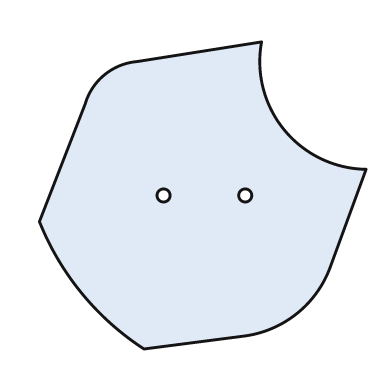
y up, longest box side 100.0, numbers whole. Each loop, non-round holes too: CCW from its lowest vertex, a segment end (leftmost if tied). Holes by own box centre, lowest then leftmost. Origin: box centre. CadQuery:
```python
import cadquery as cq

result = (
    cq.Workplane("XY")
    .moveTo(-18.0, -47.0)
    .lineTo(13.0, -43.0)
    .threePointArc((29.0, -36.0), (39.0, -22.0))
    .lineTo(50.0, 8.0)
    .threePointArc((25.0, 20.0), (18.0, 47.0))
    .lineTo(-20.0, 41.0)
    .threePointArc((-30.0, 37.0), (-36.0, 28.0))
    .lineTo(-50.0, -8.0)
    .threePointArc((-37.0, -30.0), (-18.0, -47.0))
    .close()
    .moveTo(-12.0, 0.0)
    .circle(2.0)
    .moveTo(13.0, 0.0)
    .circle(2.0)
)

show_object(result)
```